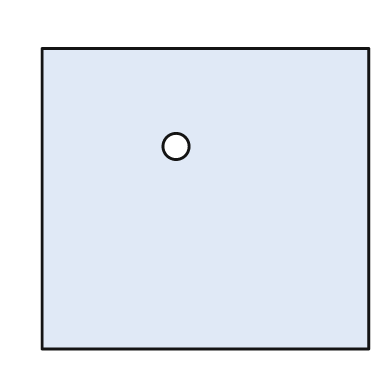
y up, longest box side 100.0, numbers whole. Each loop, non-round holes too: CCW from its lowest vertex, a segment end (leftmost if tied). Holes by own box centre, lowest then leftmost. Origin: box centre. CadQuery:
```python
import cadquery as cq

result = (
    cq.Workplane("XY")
    .moveTo(-50.0, -46.0)
    .lineTo(50.0, -46.0)
    .lineTo(50.0, 46.0)
    .lineTo(-50.0, 46.0)
    .close()
    .moveTo(-9.0, 16.0)
    .circle(4.0)
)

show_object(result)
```